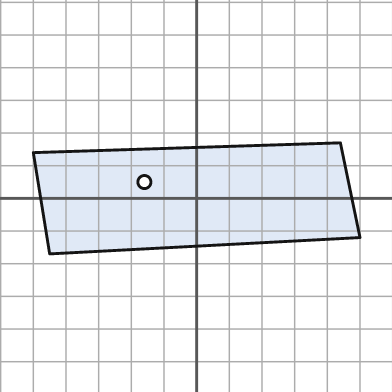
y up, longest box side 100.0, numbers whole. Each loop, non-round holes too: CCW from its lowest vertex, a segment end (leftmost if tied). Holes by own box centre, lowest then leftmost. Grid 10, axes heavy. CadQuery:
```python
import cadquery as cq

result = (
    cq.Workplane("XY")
    .moveTo(-45.0, -17.0)
    .lineTo(50.0, -12.0)
    .lineTo(44.0, 17.0)
    .lineTo(-50.0, 14.0)
    .close()
    .moveTo(-16.0, 5.0)
    .circle(2.0)
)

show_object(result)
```